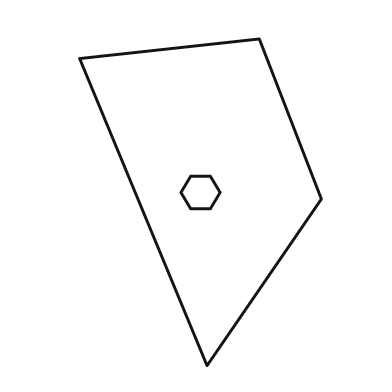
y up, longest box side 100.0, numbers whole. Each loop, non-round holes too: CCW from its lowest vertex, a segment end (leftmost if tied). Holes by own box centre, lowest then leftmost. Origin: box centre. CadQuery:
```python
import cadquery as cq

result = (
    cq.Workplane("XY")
    .moveTo(2.0, -50.0)
    .lineTo(37.0, 1.0)
    .lineTo(18.0, 50.0)
    .lineTo(-37.0, 44.0)
    .close()
    .moveTo(-3.0, -2.0)
    .lineTo(3.0, -2.0)
    .lineTo(6.0, 3.0)
    .lineTo(3.0, 8.0)
    .lineTo(-3.0, 8.0)
    .lineTo(-6.0, 3.0)
    .close()
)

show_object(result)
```